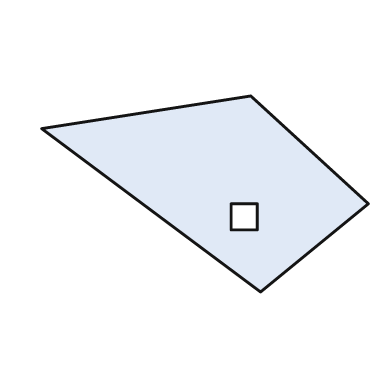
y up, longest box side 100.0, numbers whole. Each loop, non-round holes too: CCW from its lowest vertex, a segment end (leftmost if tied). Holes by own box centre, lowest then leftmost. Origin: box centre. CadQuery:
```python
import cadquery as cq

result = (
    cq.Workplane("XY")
    .moveTo(17.0, -30.0)
    .lineTo(50.0, -3.0)
    .lineTo(14.0, 30.0)
    .lineTo(-50.0, 20.0)
    .close()
    .moveTo(8.0, -11.0)
    .lineTo(16.0, -11.0)
    .lineTo(16.0, -3.0)
    .lineTo(8.0, -3.0)
    .close()
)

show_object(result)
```